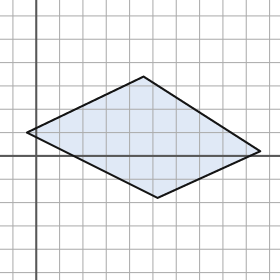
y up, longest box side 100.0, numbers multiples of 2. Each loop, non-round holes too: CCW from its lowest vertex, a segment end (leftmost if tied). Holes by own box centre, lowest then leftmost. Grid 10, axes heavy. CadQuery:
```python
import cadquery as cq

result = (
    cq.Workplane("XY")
    .moveTo(52.0, -18.0)
    .lineTo(96.0, 2.0)
    .lineTo(46.0, 34.0)
    .lineTo(-4.0, 10.0)
    .close()
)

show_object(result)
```